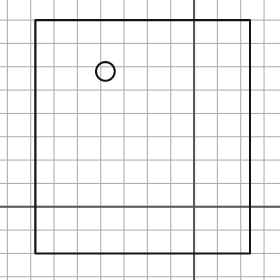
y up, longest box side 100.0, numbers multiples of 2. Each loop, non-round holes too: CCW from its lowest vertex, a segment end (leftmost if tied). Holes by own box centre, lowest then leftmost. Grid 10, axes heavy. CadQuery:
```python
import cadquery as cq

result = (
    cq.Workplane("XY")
    .moveTo(-68.0, -20.0)
    .lineTo(24.0, -20.0)
    .lineTo(24.0, 80.0)
    .lineTo(-68.0, 80.0)
    .close()
    .moveTo(-38.0, 58.0)
    .circle(4.0)
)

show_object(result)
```